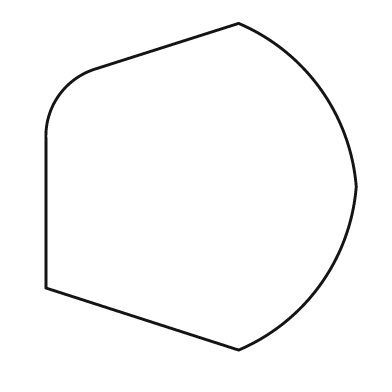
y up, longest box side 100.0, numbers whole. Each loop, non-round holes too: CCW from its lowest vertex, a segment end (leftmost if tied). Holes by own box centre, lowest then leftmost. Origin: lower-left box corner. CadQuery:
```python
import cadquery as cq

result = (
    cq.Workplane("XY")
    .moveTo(59.0, 0.0)
    .threePointArc((84.0, 20.0), (95.0, 50.0))
    .threePointArc((84.0, 80.0), (59.0, 100.0))
    .lineTo(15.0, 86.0)
    .threePointArc((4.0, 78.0), (0.0, 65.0))
    .lineTo(0.0, 19.0)
    .close()
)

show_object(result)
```